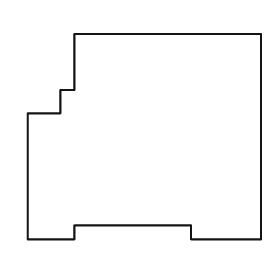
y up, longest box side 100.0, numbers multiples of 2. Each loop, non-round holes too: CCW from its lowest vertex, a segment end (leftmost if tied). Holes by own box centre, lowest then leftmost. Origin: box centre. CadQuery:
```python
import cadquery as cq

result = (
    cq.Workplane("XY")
    .moveTo(-50.0, -44.0)
    .lineTo(-30.0, -44.0)
    .lineTo(-30.0, -38.0)
    .lineTo(20.0, -38.0)
    .lineTo(20.0, -44.0)
    .lineTo(50.0, -44.0)
    .lineTo(50.0, 44.0)
    .lineTo(-30.0, 44.0)
    .lineTo(-30.0, 20.0)
    .lineTo(-36.0, 20.0)
    .lineTo(-36.0, 10.0)
    .lineTo(-50.0, 10.0)
    .close()
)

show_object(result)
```